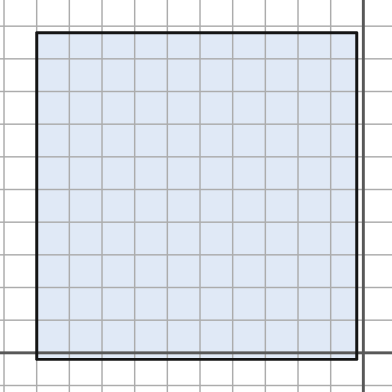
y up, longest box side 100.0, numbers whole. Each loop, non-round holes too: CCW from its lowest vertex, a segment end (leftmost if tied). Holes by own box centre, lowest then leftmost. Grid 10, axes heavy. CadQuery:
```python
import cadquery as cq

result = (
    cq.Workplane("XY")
    .moveTo(-100.0, -2.0)
    .lineTo(-2.0, -2.0)
    .lineTo(-2.0, 98.0)
    .lineTo(-100.0, 98.0)
    .close()
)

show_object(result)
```